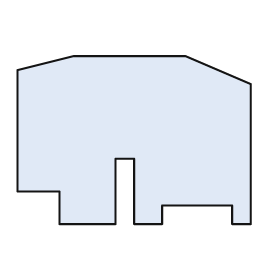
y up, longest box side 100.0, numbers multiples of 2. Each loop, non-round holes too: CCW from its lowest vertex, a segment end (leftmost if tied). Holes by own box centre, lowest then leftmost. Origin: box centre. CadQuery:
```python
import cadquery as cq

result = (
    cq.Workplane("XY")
    .moveTo(-32.0, -36.0)
    .lineTo(-8.0, -36.0)
    .lineTo(-8.0, -8.0)
    .lineTo(0.0, -8.0)
    .lineTo(0.0, -36.0)
    .lineTo(12.0, -36.0)
    .lineTo(12.0, -28.0)
    .lineTo(42.0, -28.0)
    .lineTo(42.0, -36.0)
    .lineTo(50.0, -36.0)
    .lineTo(50.0, 24.0)
    .lineTo(22.0, 36.0)
    .lineTo(-26.0, 36.0)
    .lineTo(-50.0, 30.0)
    .lineTo(-50.0, -22.0)
    .lineTo(-32.0, -22.0)
    .close()
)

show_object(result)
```